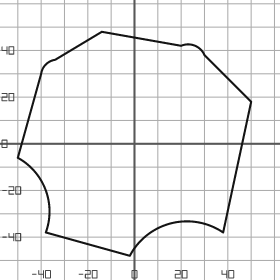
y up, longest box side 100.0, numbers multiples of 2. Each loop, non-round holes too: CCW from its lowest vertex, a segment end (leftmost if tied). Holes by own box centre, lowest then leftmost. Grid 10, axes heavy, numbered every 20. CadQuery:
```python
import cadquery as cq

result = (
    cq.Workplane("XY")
    .moveTo(-2.0, -48.0)
    .threePointArc((16.0, -34.0), (38.0, -38.0))
    .lineTo(50.0, 18.0)
    .lineTo(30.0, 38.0)
    .threePointArc((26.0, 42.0), (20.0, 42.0))
    .lineTo(-14.0, 48.0)
    .lineTo(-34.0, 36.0)
    .threePointArc((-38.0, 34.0), (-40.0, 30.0))
    .lineTo(-50.0, -6.0)
    .threePointArc((-38.0, -20.0), (-38.0, -38.0))
    .close()
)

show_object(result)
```